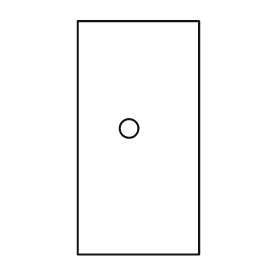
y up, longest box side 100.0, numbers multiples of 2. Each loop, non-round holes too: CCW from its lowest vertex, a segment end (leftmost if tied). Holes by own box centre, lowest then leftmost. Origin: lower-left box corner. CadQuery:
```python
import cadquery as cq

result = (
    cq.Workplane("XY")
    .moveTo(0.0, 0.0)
    .lineTo(52.0, 0.0)
    .lineTo(52.0, 100.0)
    .lineTo(0.0, 100.0)
    .close()
    .moveTo(22.0, 54.0)
    .circle(4.0)
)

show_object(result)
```